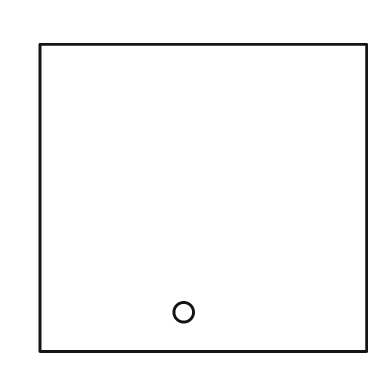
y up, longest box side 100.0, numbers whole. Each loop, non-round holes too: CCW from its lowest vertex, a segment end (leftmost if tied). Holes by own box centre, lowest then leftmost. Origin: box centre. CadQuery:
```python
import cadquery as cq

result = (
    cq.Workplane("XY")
    .moveTo(-50.0, -47.0)
    .lineTo(50.0, -47.0)
    .lineTo(50.0, 47.0)
    .lineTo(-50.0, 47.0)
    .close()
    .moveTo(-6.0, -35.0)
    .circle(3.0)
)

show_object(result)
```